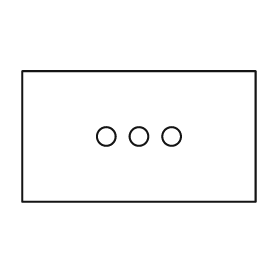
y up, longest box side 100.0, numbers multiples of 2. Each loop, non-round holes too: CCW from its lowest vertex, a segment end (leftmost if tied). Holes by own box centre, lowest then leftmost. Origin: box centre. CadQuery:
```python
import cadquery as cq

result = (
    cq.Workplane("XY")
    .moveTo(-50.0, -28.0)
    .lineTo(50.0, -28.0)
    .lineTo(50.0, 28.0)
    .lineTo(-50.0, 28.0)
    .close()
    .moveTo(-14.0, 0.0)
    .circle(4.0)
    .moveTo(0.0, 0.0)
    .circle(4.0)
    .moveTo(14.0, 0.0)
    .circle(4.0)
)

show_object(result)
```